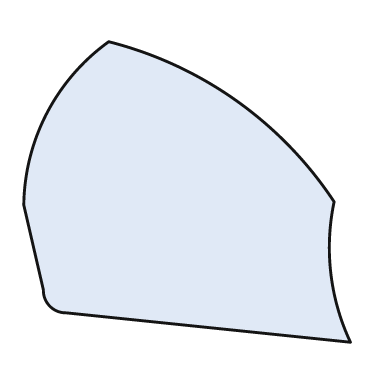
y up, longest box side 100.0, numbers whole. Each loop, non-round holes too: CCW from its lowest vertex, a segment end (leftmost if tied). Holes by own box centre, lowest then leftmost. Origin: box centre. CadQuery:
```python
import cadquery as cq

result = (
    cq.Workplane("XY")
    .moveTo(50.0, -46.0)
    .threePointArc((44.0, -25.0), (45.0, -3.0))
    .threePointArc((15.0, 28.0), (-24.0, 46.0))
    .threePointArc((-43.0, 24.0), (-50.0, -4.0))
    .lineTo(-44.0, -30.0)
    .threePointArc((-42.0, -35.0), (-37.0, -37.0))
    .close()
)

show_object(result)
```